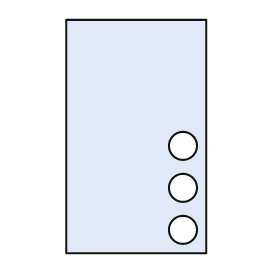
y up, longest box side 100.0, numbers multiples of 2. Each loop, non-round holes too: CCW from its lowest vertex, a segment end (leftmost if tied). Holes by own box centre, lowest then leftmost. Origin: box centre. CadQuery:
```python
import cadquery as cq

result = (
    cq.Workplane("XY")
    .moveTo(-30.0, -50.0)
    .lineTo(30.0, -50.0)
    .lineTo(30.0, 50.0)
    .lineTo(-30.0, 50.0)
    .close()
    .moveTo(20.0, -40.0)
    .circle(6.0)
    .moveTo(20.0, -22.0)
    .circle(6.0)
    .moveTo(20.0, -4.0)
    .circle(6.0)
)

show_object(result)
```